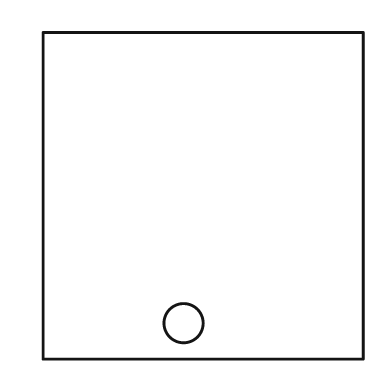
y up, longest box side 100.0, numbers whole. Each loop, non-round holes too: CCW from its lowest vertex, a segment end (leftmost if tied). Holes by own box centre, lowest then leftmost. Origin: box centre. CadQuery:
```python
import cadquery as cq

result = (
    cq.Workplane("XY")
    .moveTo(-49.0, -50.0)
    .lineTo(49.0, -50.0)
    .lineTo(49.0, 50.0)
    .lineTo(-49.0, 50.0)
    .close()
    .moveTo(-6.0, -39.0)
    .circle(6.0)
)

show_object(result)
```